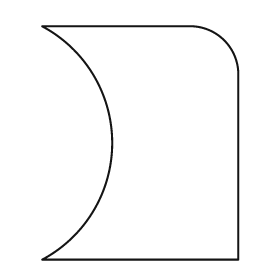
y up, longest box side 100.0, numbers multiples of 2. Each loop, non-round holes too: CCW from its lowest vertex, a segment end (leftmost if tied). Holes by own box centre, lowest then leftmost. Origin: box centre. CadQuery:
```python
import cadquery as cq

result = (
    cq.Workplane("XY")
    .moveTo(-42.0, -50.0)
    .lineTo(42.0, -50.0)
    .lineTo(42.0, 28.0)
    .threePointArc((36.0, 44.0), (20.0, 50.0))
    .lineTo(-42.0, 50.0)
    .threePointArc((-12.0, 0.0), (-42.0, -50.0))
    .close()
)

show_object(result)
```